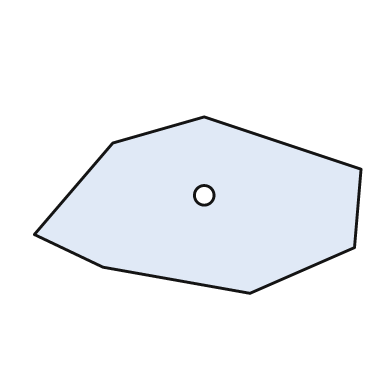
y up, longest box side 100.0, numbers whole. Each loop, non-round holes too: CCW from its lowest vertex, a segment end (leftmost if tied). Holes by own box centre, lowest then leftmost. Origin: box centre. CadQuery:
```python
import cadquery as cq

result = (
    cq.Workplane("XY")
    .moveTo(16.0, -27.0)
    .lineTo(48.0, -13.0)
    .lineTo(50.0, 11.0)
    .lineTo(2.0, 27.0)
    .lineTo(-26.0, 19.0)
    .lineTo(-50.0, -9.0)
    .lineTo(-29.0, -19.0)
    .close()
    .moveTo(2.0, 3.0)
    .circle(3.0)
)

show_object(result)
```